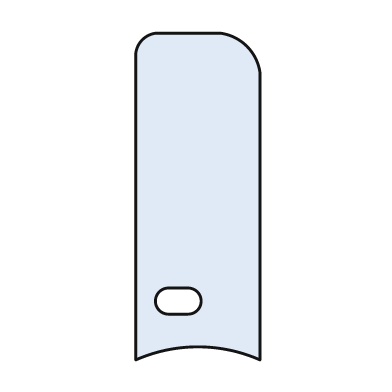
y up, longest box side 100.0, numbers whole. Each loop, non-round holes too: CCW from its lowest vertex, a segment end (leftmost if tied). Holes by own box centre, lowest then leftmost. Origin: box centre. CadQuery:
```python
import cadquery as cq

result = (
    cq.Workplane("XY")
    .moveTo(-19.0, -50.0)
    .threePointArc((0.0, -46.0), (19.0, -50.0))
    .lineTo(19.0, 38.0)
    .threePointArc((15.0, 46.0), (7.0, 50.0))
    .lineTo(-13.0, 50.0)
    .threePointArc((-17.0, 48.0), (-19.0, 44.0))
    .close()
    .moveTo(-9.0, -36.0)
    .lineTo(-3.0, -36.0)
    .threePointArc((1.0, -32.0), (-3.0, -28.0))
    .lineTo(-9.0, -28.0)
    .threePointArc((-13.0, -32.0), (-9.0, -36.0))
    .close()
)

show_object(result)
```